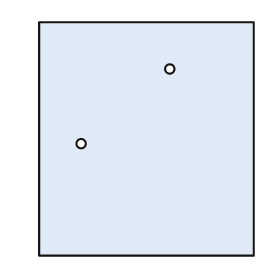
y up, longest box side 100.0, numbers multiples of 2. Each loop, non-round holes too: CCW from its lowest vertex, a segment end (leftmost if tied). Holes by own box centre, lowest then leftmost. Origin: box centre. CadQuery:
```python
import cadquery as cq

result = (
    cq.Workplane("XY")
    .moveTo(-46.0, -50.0)
    .lineTo(46.0, -50.0)
    .lineTo(46.0, 50.0)
    .lineTo(-46.0, 50.0)
    .close()
    .moveTo(-28.0, -2.0)
    .circle(2.0)
    .moveTo(10.0, 30.0)
    .circle(2.0)
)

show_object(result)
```